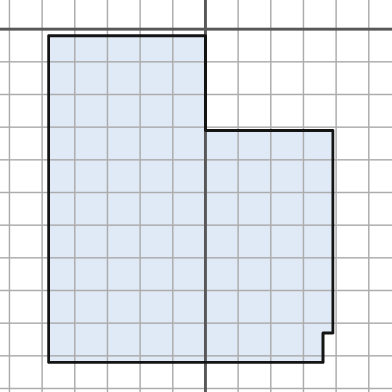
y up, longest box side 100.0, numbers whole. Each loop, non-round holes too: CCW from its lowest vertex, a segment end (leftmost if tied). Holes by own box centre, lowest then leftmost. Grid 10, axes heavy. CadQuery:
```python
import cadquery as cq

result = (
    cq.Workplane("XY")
    .moveTo(-48.0, -102.0)
    .lineTo(36.0, -102.0)
    .lineTo(36.0, -93.0)
    .lineTo(39.0, -93.0)
    .lineTo(39.0, -31.0)
    .lineTo(0.0, -31.0)
    .lineTo(0.0, -2.0)
    .lineTo(-48.0, -2.0)
    .close()
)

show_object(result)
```